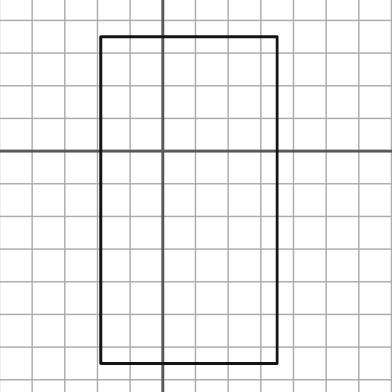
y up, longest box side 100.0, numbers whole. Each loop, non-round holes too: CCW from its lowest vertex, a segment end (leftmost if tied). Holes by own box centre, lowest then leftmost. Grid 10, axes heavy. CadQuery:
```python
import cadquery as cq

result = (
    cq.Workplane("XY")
    .moveTo(-19.0, -65.0)
    .lineTo(35.0, -65.0)
    .lineTo(35.0, 35.0)
    .lineTo(-19.0, 35.0)
    .close()
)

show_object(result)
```